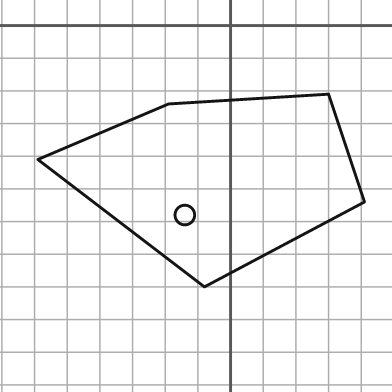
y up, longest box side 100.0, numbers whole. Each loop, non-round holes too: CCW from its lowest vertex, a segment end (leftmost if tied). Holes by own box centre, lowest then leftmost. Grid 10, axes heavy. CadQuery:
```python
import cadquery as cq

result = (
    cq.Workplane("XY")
    .moveTo(-8.0, -80.0)
    .lineTo(41.0, -54.0)
    .lineTo(30.0, -21.0)
    .lineTo(-19.0, -24.0)
    .lineTo(-59.0, -41.0)
    .close()
    .moveTo(-14.0, -58.0)
    .circle(3.0)
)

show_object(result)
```